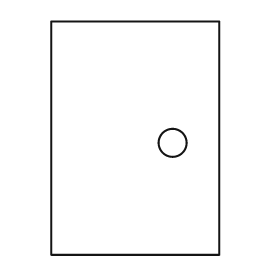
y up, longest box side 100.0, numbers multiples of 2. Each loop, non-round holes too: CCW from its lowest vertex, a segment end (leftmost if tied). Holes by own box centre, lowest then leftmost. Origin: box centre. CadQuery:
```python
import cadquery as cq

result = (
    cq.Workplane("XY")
    .moveTo(-36.0, -50.0)
    .lineTo(36.0, -50.0)
    .lineTo(36.0, 50.0)
    .lineTo(-36.0, 50.0)
    .close()
    .moveTo(16.0, -2.0)
    .circle(6.0)
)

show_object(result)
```